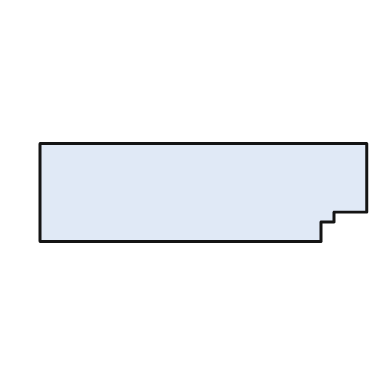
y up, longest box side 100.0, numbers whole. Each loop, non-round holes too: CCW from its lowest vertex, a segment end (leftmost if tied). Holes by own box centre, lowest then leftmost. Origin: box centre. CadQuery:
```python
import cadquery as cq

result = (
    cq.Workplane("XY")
    .moveTo(-50.0, -15.0)
    .lineTo(36.0, -15.0)
    .lineTo(36.0, -9.0)
    .lineTo(40.0, -9.0)
    .lineTo(40.0, -6.0)
    .lineTo(50.0, -6.0)
    .lineTo(50.0, 15.0)
    .lineTo(-50.0, 15.0)
    .close()
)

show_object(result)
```